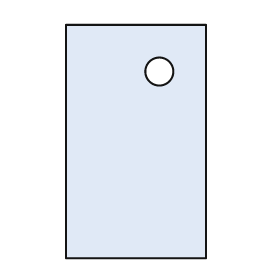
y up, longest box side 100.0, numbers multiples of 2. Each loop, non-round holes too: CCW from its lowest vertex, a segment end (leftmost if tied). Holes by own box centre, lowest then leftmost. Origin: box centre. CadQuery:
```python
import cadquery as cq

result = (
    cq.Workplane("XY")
    .moveTo(-30.0, -50.0)
    .lineTo(30.0, -50.0)
    .lineTo(30.0, 50.0)
    .lineTo(-30.0, 50.0)
    .close()
    .moveTo(10.0, 30.0)
    .circle(6.0)
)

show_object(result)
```